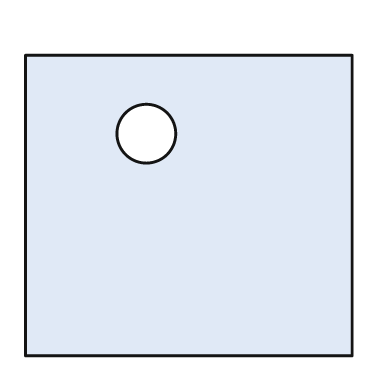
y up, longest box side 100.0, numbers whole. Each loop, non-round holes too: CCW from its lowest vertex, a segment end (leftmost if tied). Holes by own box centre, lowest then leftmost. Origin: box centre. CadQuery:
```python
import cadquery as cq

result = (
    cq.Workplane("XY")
    .moveTo(-50.0, -46.0)
    .lineTo(50.0, -46.0)
    .lineTo(50.0, 46.0)
    .lineTo(-50.0, 46.0)
    .close()
    .moveTo(-13.0, 22.0)
    .circle(9.0)
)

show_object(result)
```